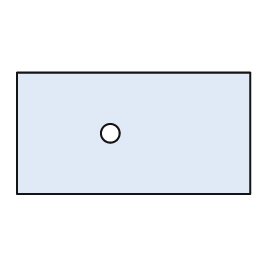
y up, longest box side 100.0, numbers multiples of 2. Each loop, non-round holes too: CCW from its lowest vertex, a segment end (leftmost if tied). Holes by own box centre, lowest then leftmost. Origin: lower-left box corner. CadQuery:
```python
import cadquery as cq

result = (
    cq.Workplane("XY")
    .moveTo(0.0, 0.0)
    .lineTo(100.0, 0.0)
    .lineTo(100.0, 52.0)
    .lineTo(0.0, 52.0)
    .close()
    .moveTo(40.0, 26.0)
    .circle(4.0)
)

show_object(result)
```